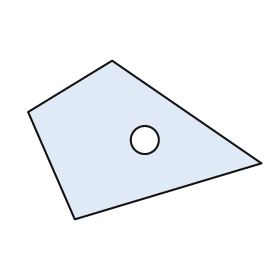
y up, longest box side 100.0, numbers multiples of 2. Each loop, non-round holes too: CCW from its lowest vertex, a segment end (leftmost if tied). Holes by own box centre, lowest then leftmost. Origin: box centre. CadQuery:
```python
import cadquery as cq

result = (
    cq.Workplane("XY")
    .moveTo(-30.0, -34.0)
    .lineTo(50.0, -10.0)
    .lineTo(-14.0, 34.0)
    .lineTo(-50.0, 12.0)
    .close()
    .moveTo(0.0, 0.0)
    .circle(6.0)
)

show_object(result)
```